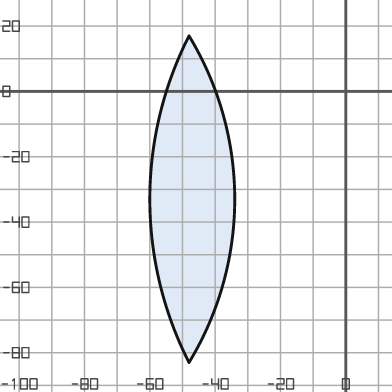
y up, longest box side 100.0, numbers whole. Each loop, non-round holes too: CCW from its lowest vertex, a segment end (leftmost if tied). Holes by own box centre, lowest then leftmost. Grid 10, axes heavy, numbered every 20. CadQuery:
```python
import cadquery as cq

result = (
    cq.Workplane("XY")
    .moveTo(-48.0, -83.0)
    .threePointArc((-34.0, -33.0), (-48.0, 17.0))
    .threePointArc((-60.0, -33.0), (-48.0, -83.0))
    .close()
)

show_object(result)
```